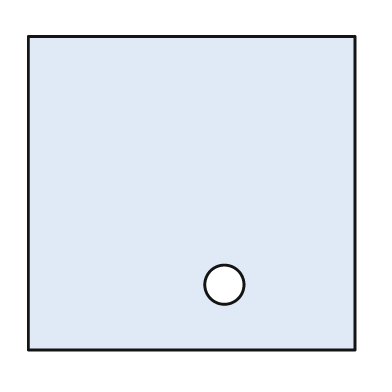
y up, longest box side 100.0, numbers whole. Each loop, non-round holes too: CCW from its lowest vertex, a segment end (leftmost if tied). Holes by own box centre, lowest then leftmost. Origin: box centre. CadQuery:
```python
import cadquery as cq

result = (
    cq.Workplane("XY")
    .moveTo(-50.0, -48.0)
    .lineTo(50.0, -48.0)
    .lineTo(50.0, 48.0)
    .lineTo(-50.0, 48.0)
    .close()
    .moveTo(10.0, -28.0)
    .circle(6.0)
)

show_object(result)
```